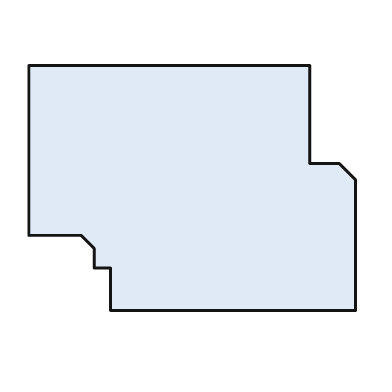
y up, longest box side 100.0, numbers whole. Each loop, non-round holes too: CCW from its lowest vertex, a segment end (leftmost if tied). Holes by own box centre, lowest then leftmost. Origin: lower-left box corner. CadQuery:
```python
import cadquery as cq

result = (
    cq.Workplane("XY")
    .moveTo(25.0, 0.0)
    .lineTo(100.0, 0.0)
    .lineTo(100.0, 40.0)
    .lineTo(95.0, 45.0)
    .lineTo(86.0, 45.0)
    .lineTo(86.0, 75.0)
    .lineTo(0.0, 75.0)
    .lineTo(0.0, 23.0)
    .lineTo(16.0, 23.0)
    .lineTo(20.0, 19.0)
    .lineTo(20.0, 13.0)
    .lineTo(25.0, 13.0)
    .close()
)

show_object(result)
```